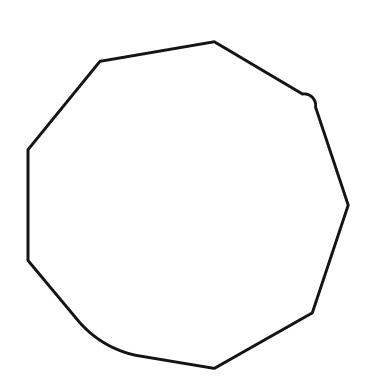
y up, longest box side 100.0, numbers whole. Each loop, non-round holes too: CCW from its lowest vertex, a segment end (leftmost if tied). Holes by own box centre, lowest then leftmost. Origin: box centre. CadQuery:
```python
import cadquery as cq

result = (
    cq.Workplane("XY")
    .moveTo(8.0, -50.0)
    .lineTo(38.0, -33.0)
    .lineTo(49.0, 0.0)
    .lineTo(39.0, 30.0)
    .threePointArc((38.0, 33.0), (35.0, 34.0))
    .lineTo(8.0, 50.0)
    .lineTo(-27.0, 44.0)
    .lineTo(-49.0, 17.0)
    .lineTo(-49.0, -17.0)
    .lineTo(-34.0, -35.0)
    .threePointArc((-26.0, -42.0), (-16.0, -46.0))
    .close()
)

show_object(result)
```